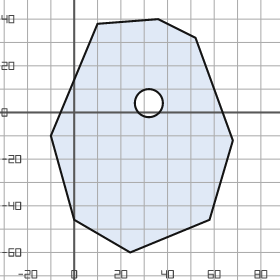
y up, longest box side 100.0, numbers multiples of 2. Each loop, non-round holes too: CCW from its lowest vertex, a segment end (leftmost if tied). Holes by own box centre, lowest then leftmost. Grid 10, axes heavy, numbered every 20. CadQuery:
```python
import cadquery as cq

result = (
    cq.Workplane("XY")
    .moveTo(24.0, -60.0)
    .lineTo(58.0, -46.0)
    .lineTo(68.0, -12.0)
    .lineTo(52.0, 32.0)
    .lineTo(36.0, 40.0)
    .lineTo(10.0, 38.0)
    .lineTo(-10.0, -10.0)
    .lineTo(0.0, -46.0)
    .close()
    .moveTo(32.0, 4.0)
    .circle(6.0)
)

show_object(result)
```